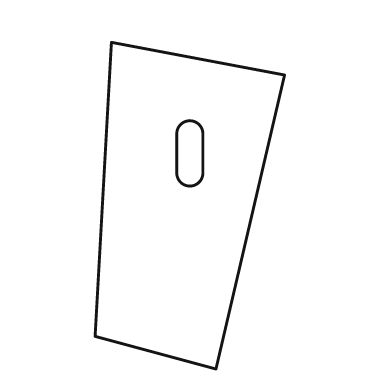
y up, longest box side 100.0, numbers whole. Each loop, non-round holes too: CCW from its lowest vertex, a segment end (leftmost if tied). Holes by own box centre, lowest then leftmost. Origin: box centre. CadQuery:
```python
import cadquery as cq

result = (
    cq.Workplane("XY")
    .moveTo(8.0, -50.0)
    .lineTo(29.0, 40.0)
    .lineTo(-24.0, 50.0)
    .lineTo(-29.0, -40.0)
    .close()
    .moveTo(-4.0, 10.0)
    .threePointArc((0.0, 6.0), (4.0, 10.0))
    .lineTo(4.0, 22.0)
    .threePointArc((0.0, 26.0), (-4.0, 22.0))
    .close()
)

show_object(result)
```